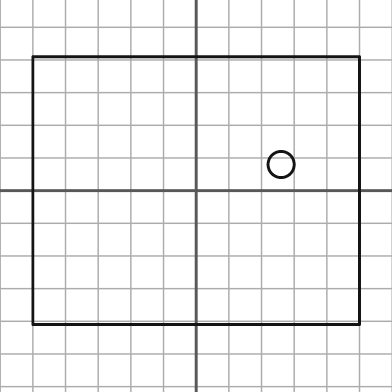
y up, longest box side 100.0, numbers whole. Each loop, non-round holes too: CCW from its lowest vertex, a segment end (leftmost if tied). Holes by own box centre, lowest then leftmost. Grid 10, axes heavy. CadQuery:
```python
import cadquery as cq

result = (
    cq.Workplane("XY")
    .moveTo(-50.0, -41.0)
    .lineTo(50.0, -41.0)
    .lineTo(50.0, 41.0)
    .lineTo(-50.0, 41.0)
    .close()
    .moveTo(26.0, 8.0)
    .circle(4.0)
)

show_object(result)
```